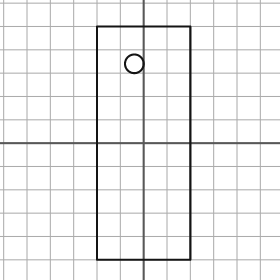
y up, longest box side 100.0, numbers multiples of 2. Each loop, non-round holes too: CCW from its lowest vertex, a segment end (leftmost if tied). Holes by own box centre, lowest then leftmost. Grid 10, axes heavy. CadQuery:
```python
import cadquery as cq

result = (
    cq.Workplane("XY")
    .moveTo(-20.0, -50.0)
    .lineTo(20.0, -50.0)
    .lineTo(20.0, 50.0)
    .lineTo(-20.0, 50.0)
    .close()
    .moveTo(-4.0, 34.0)
    .circle(4.0)
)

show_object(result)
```